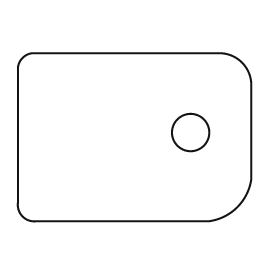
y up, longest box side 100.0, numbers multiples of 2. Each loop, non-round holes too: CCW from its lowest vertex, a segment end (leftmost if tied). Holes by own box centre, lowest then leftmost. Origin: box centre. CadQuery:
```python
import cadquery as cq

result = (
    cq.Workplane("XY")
    .moveTo(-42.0, -36.0)
    .lineTo(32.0, -36.0)
    .threePointArc((44.0, -30.0), (50.0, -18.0))
    .lineTo(50.0, 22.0)
    .threePointArc((46.0, 32.0), (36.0, 36.0))
    .lineTo(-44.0, 36.0)
    .threePointArc((-48.0, 34.0), (-50.0, 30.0))
    .lineTo(-50.0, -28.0)
    .threePointArc((-48.0, -34.0), (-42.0, -36.0))
    .close()
    .moveTo(24.0, 2.0)
    .circle(8.0)
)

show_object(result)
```